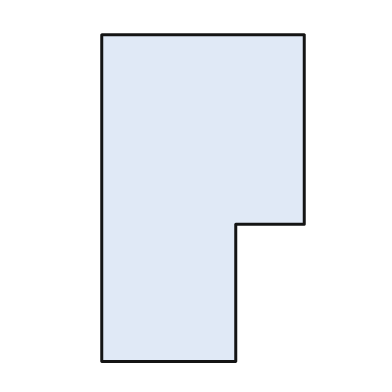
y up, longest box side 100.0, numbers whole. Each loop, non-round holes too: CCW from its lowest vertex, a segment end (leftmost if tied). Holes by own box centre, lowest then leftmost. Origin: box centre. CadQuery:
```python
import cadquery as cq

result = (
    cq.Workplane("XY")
    .moveTo(-31.0, -50.0)
    .lineTo(10.0, -50.0)
    .lineTo(10.0, -8.0)
    .lineTo(31.0, -8.0)
    .lineTo(31.0, 50.0)
    .lineTo(-31.0, 50.0)
    .close()
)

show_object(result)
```